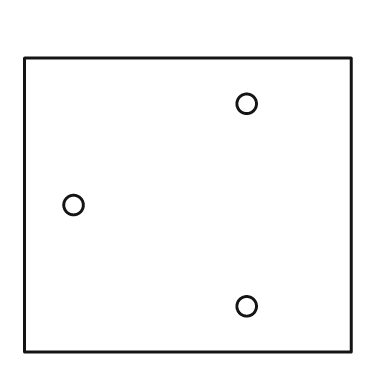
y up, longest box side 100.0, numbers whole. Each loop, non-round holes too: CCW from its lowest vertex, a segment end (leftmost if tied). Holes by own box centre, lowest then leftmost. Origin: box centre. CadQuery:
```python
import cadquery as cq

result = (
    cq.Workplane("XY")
    .moveTo(-50.0, -45.0)
    .lineTo(50.0, -45.0)
    .lineTo(50.0, 45.0)
    .lineTo(-50.0, 45.0)
    .close()
    .moveTo(18.0, -31.0)
    .circle(3.0)
    .moveTo(-35.0, 0.0)
    .circle(3.0)
    .moveTo(18.0, 31.0)
    .circle(3.0)
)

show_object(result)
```